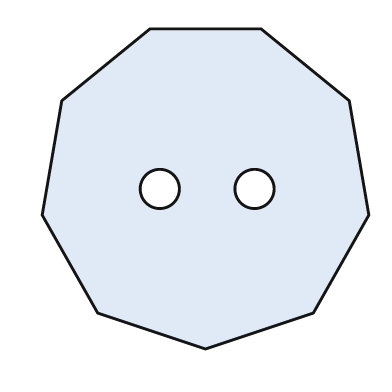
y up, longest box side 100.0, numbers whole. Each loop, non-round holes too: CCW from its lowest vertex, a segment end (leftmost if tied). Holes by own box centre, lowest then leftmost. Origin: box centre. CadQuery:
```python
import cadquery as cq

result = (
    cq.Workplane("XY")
    .moveTo(0.0, -49.0)
    .lineTo(33.0, -38.0)
    .lineTo(50.0, -8.0)
    .lineTo(44.0, 27.0)
    .lineTo(17.0, 49.0)
    .lineTo(-17.0, 49.0)
    .lineTo(-44.0, 27.0)
    .lineTo(-50.0, -8.0)
    .lineTo(-33.0, -38.0)
    .close()
    .moveTo(-14.0, 0.0)
    .circle(6.0)
    .moveTo(15.0, 0.0)
    .circle(6.0)
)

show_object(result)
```